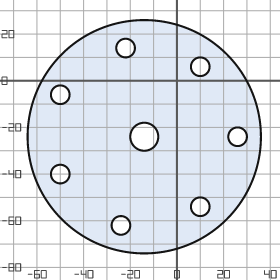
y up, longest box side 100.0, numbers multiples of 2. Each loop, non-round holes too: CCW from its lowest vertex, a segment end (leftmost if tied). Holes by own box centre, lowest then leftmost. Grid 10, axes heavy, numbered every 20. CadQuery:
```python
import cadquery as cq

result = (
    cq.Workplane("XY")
    .moveTo(-14.0, -24.0)
    .circle(50.0)
    .moveTo(-24.0, -62.0)
    .circle(4.0)
    .moveTo(10.0, -54.0)
    .circle(4.0)
    .moveTo(-50.0, -40.0)
    .circle(4.0)
    .moveTo(-14.0, -24.0)
    .circle(6.0)
    .moveTo(26.0, -24.0)
    .circle(4.0)
    .moveTo(-50.0, -6.0)
    .circle(4.0)
    .moveTo(10.0, 6.0)
    .circle(4.0)
    .moveTo(-22.0, 14.0)
    .circle(4.0)
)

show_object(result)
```